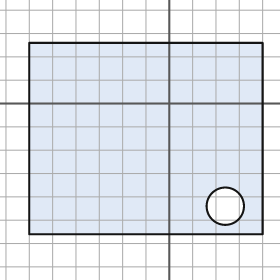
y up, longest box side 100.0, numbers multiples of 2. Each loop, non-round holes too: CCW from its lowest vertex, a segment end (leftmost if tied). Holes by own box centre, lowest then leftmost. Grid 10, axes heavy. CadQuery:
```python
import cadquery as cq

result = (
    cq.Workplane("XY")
    .moveTo(-60.0, -56.0)
    .lineTo(40.0, -56.0)
    .lineTo(40.0, 26.0)
    .lineTo(-60.0, 26.0)
    .close()
    .moveTo(24.0, -44.0)
    .circle(8.0)
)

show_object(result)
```